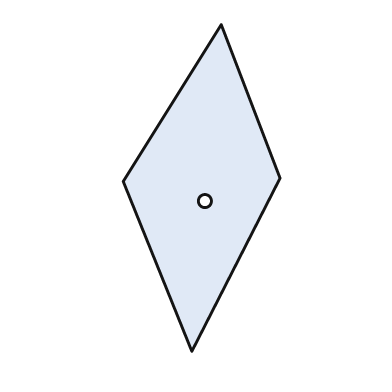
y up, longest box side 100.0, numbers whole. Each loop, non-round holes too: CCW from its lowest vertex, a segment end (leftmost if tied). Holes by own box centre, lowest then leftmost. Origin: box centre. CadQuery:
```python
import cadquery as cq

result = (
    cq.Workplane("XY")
    .moveTo(-3.0, -50.0)
    .lineTo(24.0, 3.0)
    .lineTo(6.0, 50.0)
    .lineTo(-24.0, 2.0)
    .close()
    .moveTo(1.0, -4.0)
    .circle(2.0)
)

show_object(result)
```